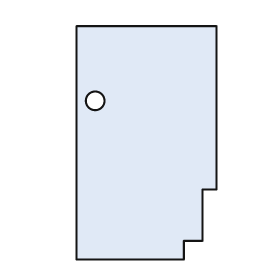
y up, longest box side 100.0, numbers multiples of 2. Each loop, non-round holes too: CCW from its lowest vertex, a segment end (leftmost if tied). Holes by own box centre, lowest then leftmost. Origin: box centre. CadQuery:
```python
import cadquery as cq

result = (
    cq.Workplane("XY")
    .moveTo(-30.0, -50.0)
    .lineTo(16.0, -50.0)
    .lineTo(16.0, -42.0)
    .lineTo(24.0, -42.0)
    .lineTo(24.0, -20.0)
    .lineTo(30.0, -20.0)
    .lineTo(30.0, 50.0)
    .lineTo(-30.0, 50.0)
    .close()
    .moveTo(-22.0, 18.0)
    .circle(4.0)
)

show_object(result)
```